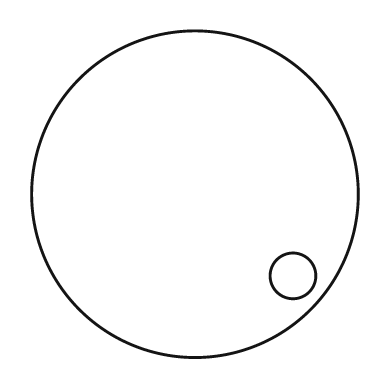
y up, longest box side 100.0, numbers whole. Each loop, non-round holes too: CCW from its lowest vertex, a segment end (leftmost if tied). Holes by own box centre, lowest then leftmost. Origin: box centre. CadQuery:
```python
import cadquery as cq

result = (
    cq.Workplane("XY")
    .moveTo(0.0, 0.0)
    .circle(50.0)
    .moveTo(30.0, -25.0)
    .circle(7.0)
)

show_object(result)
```